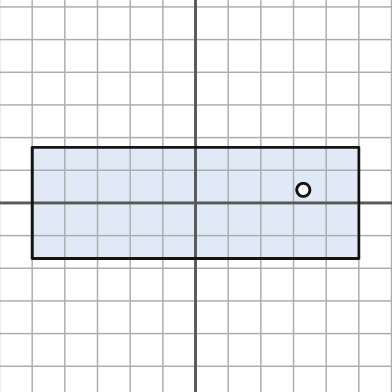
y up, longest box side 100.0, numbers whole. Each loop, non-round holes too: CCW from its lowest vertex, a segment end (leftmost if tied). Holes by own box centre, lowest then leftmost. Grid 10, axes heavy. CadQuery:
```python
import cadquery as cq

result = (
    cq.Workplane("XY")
    .moveTo(-50.0, -17.0)
    .lineTo(50.0, -17.0)
    .lineTo(50.0, 17.0)
    .lineTo(-50.0, 17.0)
    .close()
    .moveTo(33.0, 4.0)
    .circle(2.0)
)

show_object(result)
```